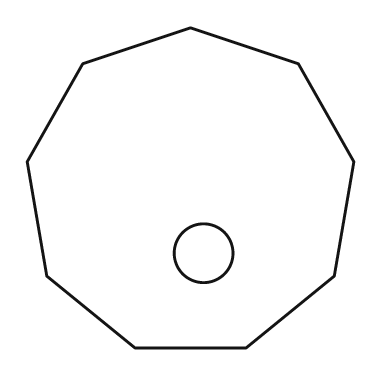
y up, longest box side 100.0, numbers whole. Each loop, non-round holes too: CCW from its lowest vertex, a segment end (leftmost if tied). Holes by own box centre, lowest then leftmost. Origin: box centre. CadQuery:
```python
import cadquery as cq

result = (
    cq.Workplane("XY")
    .moveTo(-17.0, -49.0)
    .lineTo(17.0, -49.0)
    .lineTo(44.0, -27.0)
    .lineTo(50.0, 8.0)
    .lineTo(33.0, 38.0)
    .lineTo(0.0, 49.0)
    .lineTo(-33.0, 38.0)
    .lineTo(-50.0, 8.0)
    .lineTo(-44.0, -27.0)
    .close()
    .moveTo(4.0, -20.0)
    .circle(9.0)
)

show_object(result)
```